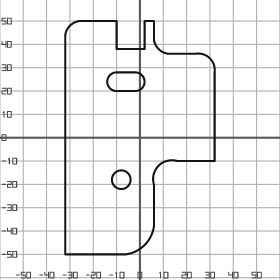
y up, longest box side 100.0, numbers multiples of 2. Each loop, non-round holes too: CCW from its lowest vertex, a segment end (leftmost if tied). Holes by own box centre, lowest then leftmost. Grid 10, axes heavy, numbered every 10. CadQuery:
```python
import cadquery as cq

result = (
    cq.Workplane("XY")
    .moveTo(-32.0, -50.0)
    .lineTo(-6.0, -50.0)
    .threePointArc((2.0, -46.0), (6.0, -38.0))
    .lineTo(6.0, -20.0)
    .threePointArc((8.0, -12.0), (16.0, -10.0))
    .lineTo(32.0, -10.0)
    .lineTo(32.0, 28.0)
    .threePointArc((30.0, 34.0), (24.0, 36.0))
    .lineTo(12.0, 36.0)
    .threePointArc((8.0, 38.0), (6.0, 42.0))
    .lineTo(6.0, 50.0)
    .lineTo(2.0, 50.0)
    .lineTo(2.0, 38.0)
    .lineTo(-10.0, 38.0)
    .lineTo(-10.0, 50.0)
    .lineTo(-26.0, 50.0)
    .threePointArc((-30.0, 48.0), (-32.0, 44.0))
    .close()
    .moveTo(-8.0, -18.0)
    .circle(4.0)
    .moveTo(-10.0, 20.0)
    .lineTo(-2.0, 20.0)
    .threePointArc((2.0, 24.0), (-2.0, 28.0))
    .lineTo(-10.0, 28.0)
    .threePointArc((-14.0, 24.0), (-10.0, 20.0))
    .close()
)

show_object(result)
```